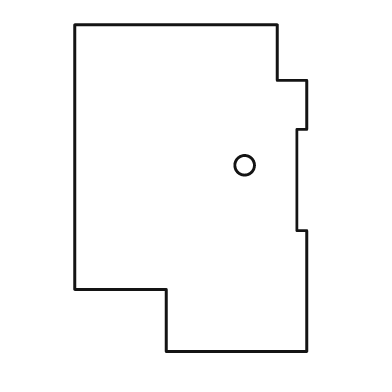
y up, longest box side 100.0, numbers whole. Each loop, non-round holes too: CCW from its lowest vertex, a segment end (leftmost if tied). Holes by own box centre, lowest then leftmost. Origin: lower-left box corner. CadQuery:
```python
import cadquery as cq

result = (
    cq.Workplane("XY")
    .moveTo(28.0, 0.0)
    .lineTo(71.0, 0.0)
    .lineTo(71.0, 37.0)
    .lineTo(68.0, 37.0)
    .lineTo(68.0, 68.0)
    .lineTo(71.0, 68.0)
    .lineTo(71.0, 83.0)
    .lineTo(62.0, 83.0)
    .lineTo(62.0, 100.0)
    .lineTo(0.0, 100.0)
    .lineTo(0.0, 19.0)
    .lineTo(28.0, 19.0)
    .close()
    .moveTo(52.0, 57.0)
    .circle(3.0)
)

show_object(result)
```